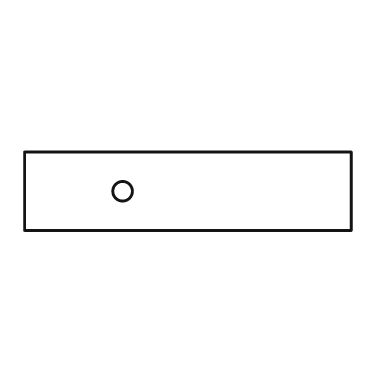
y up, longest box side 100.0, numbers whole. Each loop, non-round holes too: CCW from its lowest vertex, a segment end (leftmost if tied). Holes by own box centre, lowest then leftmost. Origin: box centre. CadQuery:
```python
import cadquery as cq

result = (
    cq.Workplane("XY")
    .moveTo(-50.0, -12.0)
    .lineTo(50.0, -12.0)
    .lineTo(50.0, 12.0)
    .lineTo(-50.0, 12.0)
    .close()
    .moveTo(-20.0, 0.0)
    .circle(3.0)
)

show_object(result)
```